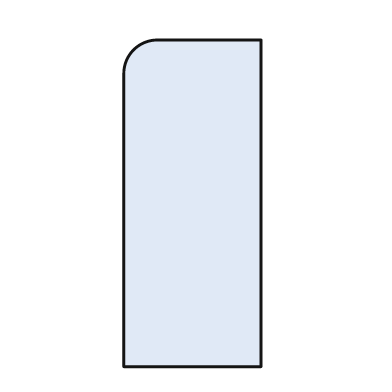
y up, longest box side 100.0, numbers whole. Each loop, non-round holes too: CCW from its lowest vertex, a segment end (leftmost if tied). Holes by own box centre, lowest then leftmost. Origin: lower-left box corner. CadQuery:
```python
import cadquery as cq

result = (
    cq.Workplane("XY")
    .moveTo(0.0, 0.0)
    .lineTo(42.0, 0.0)
    .lineTo(42.0, 100.0)
    .lineTo(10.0, 100.0)
    .threePointArc((3.0, 97.0), (0.0, 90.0))
    .close()
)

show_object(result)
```